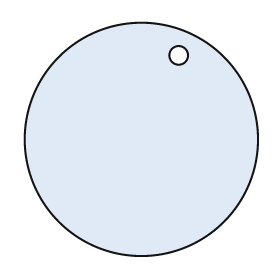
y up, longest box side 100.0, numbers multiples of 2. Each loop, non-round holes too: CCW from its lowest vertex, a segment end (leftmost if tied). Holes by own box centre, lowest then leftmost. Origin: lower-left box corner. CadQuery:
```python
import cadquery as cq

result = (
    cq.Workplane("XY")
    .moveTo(50.0, 50.0)
    .circle(50.0)
    .moveTo(66.0, 86.0)
    .circle(4.0)
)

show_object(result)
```